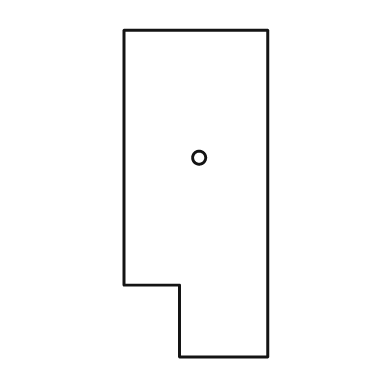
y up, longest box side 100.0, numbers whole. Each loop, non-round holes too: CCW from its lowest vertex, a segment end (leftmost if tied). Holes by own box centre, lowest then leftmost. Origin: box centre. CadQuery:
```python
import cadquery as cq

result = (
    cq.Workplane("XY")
    .moveTo(-5.0, -50.0)
    .lineTo(22.0, -50.0)
    .lineTo(22.0, 50.0)
    .lineTo(-22.0, 50.0)
    .lineTo(-22.0, -28.0)
    .lineTo(-5.0, -28.0)
    .close()
    .moveTo(1.0, 11.0)
    .circle(2.0)
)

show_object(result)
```